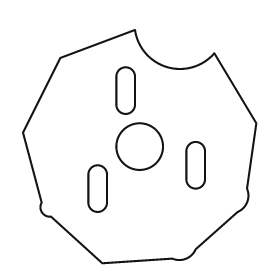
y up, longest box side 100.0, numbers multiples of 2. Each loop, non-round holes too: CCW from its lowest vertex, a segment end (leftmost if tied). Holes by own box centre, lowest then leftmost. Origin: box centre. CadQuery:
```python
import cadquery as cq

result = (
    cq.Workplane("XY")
    .moveTo(-16.0, -50.0)
    .lineTo(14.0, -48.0)
    .threePointArc((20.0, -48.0), (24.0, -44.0))
    .lineTo(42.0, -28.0)
    .threePointArc((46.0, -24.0), (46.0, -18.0))
    .lineTo(50.0, 10.0)
    .lineTo(32.0, 40.0)
    .threePointArc((12.0, 34.0), (-2.0, 50.0))
    .lineTo(-34.0, 38.0)
    .lineTo(-50.0, 6.0)
    .lineTo(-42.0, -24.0)
    .threePointArc((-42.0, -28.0), (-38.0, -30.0))
    .close()
    .moveTo(-22.0, -24.0)
    .threePointArc((-18.0, -28.0), (-14.0, -24.0))
    .lineTo(-14.0, -12.0)
    .threePointArc((-18.0, -8.0), (-22.0, -12.0))
    .close()
    .moveTo(20.0, -14.0)
    .threePointArc((24.0, -18.0), (28.0, -14.0))
    .lineTo(28.0, -2.0)
    .threePointArc((24.0, 2.0), (20.0, -2.0))
    .close()
    .moveTo(0.0, 0.0)
    .circle(10.0)
    .moveTo(-10.0, 18.0)
    .threePointArc((-6.0, 14.0), (-2.0, 18.0))
    .lineTo(-2.0, 30.0)
    .threePointArc((-6.0, 34.0), (-10.0, 30.0))
    .close()
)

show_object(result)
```